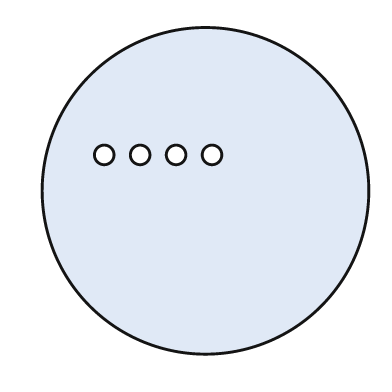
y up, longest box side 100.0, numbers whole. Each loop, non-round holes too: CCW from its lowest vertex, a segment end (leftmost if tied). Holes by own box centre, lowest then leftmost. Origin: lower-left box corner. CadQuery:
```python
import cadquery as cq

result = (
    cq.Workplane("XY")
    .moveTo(50.0, 50.0)
    .circle(50.0)
    .moveTo(19.0, 61.0)
    .circle(3.0)
    .moveTo(30.0, 61.0)
    .circle(3.0)
    .moveTo(41.0, 61.0)
    .circle(3.0)
    .moveTo(52.0, 61.0)
    .circle(3.0)
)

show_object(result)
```